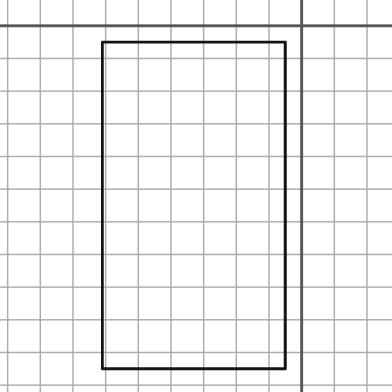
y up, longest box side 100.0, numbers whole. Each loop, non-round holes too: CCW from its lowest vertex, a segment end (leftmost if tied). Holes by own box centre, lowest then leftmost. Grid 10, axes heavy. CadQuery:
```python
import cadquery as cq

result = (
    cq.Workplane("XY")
    .moveTo(-61.0, -105.0)
    .lineTo(-5.0, -105.0)
    .lineTo(-5.0, -5.0)
    .lineTo(-61.0, -5.0)
    .close()
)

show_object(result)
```